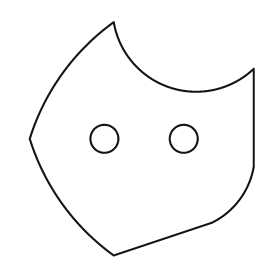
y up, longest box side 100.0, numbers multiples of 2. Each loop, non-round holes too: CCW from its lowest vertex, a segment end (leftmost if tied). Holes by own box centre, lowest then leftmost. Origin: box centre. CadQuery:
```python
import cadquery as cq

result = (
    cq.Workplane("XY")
    .moveTo(-12.0, -50.0)
    .lineTo(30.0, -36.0)
    .threePointArc((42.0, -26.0), (48.0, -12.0))
    .lineTo(48.0, 30.0)
    .threePointArc((12.0, 22.0), (-12.0, 50.0))
    .threePointArc((-34.0, 28.0), (-48.0, 0.0))
    .threePointArc((-34.0, -28.0), (-12.0, -50.0))
    .close()
    .moveTo(-16.0, 0.0)
    .circle(6.0)
    .moveTo(18.0, 0.0)
    .circle(6.0)
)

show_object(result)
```